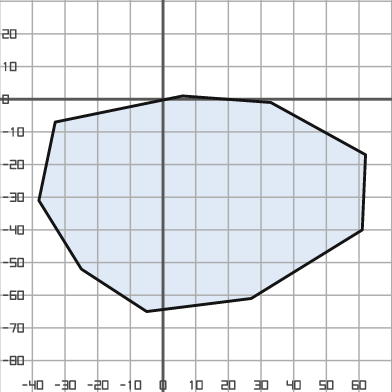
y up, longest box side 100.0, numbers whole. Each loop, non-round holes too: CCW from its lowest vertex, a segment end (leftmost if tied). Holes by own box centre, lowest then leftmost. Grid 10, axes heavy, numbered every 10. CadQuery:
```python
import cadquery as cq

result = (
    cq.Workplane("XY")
    .moveTo(-5.0, -65.0)
    .lineTo(27.0, -61.0)
    .lineTo(61.0, -40.0)
    .lineTo(62.0, -17.0)
    .lineTo(33.0, -1.0)
    .lineTo(6.0, 1.0)
    .lineTo(-33.0, -7.0)
    .lineTo(-38.0, -31.0)
    .lineTo(-25.0, -52.0)
    .close()
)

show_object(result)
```